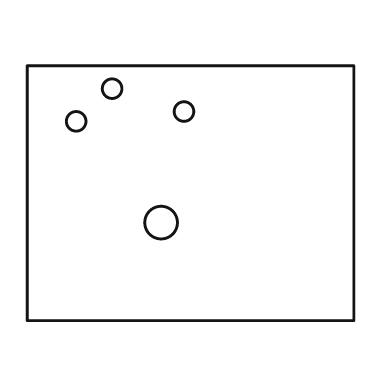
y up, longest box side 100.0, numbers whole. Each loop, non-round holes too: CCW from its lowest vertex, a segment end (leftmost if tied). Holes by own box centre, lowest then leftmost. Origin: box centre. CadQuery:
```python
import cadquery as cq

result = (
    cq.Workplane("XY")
    .moveTo(-50.0, -39.0)
    .lineTo(50.0, -39.0)
    .lineTo(50.0, 39.0)
    .lineTo(-50.0, 39.0)
    .close()
    .moveTo(-9.0, -9.0)
    .circle(5.0)
    .moveTo(-35.0, 22.0)
    .circle(3.0)
    .moveTo(-2.0, 25.0)
    .circle(3.0)
    .moveTo(-24.0, 32.0)
    .circle(3.0)
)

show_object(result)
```